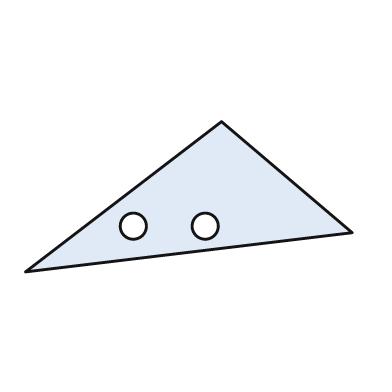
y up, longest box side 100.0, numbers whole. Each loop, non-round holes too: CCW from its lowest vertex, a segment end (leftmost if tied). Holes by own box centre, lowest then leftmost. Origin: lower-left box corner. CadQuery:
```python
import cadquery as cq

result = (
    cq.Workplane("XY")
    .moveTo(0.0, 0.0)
    .lineTo(100.0, 12.0)
    .lineTo(60.0, 46.0)
    .close()
    .moveTo(33.0, 14.0)
    .circle(4.0)
    .moveTo(55.0, 14.0)
    .circle(4.0)
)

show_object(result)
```